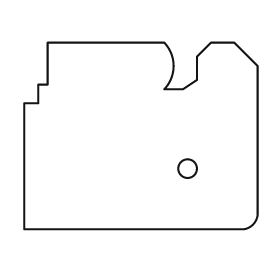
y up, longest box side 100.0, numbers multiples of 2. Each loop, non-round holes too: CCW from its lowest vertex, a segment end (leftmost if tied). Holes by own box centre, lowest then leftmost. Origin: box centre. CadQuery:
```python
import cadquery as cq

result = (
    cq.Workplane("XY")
    .moveTo(-50.0, -40.0)
    .lineTo(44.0, -40.0)
    .threePointArc((48.0, -38.0), (50.0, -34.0))
    .lineTo(50.0, 30.0)
    .lineTo(40.0, 40.0)
    .lineTo(30.0, 40.0)
    .lineTo(24.0, 34.0)
    .lineTo(24.0, 24.0)
    .lineTo(18.0, 20.0)
    .lineTo(10.0, 20.0)
    .threePointArc((14.0, 30.0), (10.0, 40.0))
    .lineTo(-40.0, 40.0)
    .lineTo(-40.0, 22.0)
    .lineTo(-44.0, 22.0)
    .lineTo(-44.0, 14.0)
    .lineTo(-50.0, 14.0)
    .close()
    .moveTo(20.0, -14.0)
    .circle(4.0)
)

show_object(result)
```